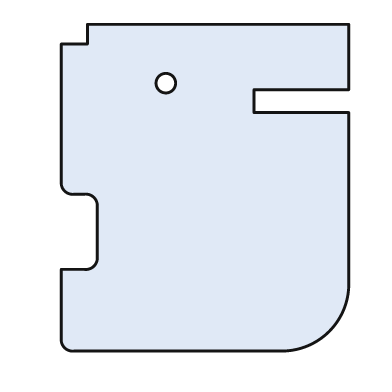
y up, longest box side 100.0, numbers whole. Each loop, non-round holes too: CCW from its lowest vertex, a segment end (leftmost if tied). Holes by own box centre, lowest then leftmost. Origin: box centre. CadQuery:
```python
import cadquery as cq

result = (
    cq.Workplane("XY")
    .moveTo(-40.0, -50.0)
    .lineTo(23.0, -50.0)
    .threePointArc((38.0, -44.0), (44.0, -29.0))
    .lineTo(44.0, 23.0)
    .lineTo(15.0, 23.0)
    .lineTo(15.0, 30.0)
    .lineTo(44.0, 30.0)
    .lineTo(44.0, 50.0)
    .lineTo(-36.0, 50.0)
    .lineTo(-36.0, 44.0)
    .lineTo(-44.0, 44.0)
    .lineTo(-44.0, 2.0)
    .threePointArc((-43.0, -1.0), (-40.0, -2.0))
    .lineTo(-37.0, -2.0)
    .threePointArc((-34.0, -3.0), (-33.0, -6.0))
    .lineTo(-33.0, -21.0)
    .threePointArc((-34.0, -24.0), (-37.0, -25.0))
    .lineTo(-44.0, -25.0)
    .lineTo(-44.0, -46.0)
    .threePointArc((-43.0, -49.0), (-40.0, -50.0))
    .close()
    .moveTo(-12.0, 32.0)
    .circle(3.0)
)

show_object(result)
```